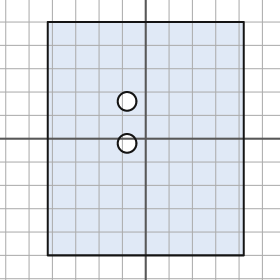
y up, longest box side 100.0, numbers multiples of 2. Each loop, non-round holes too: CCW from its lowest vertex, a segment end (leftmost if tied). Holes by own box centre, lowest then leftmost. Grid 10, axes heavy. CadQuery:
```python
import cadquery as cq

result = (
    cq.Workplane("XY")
    .moveTo(-42.0, -50.0)
    .lineTo(42.0, -50.0)
    .lineTo(42.0, 50.0)
    .lineTo(-42.0, 50.0)
    .close()
    .moveTo(-8.0, -2.0)
    .circle(4.0)
    .moveTo(-8.0, 16.0)
    .circle(4.0)
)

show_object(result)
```